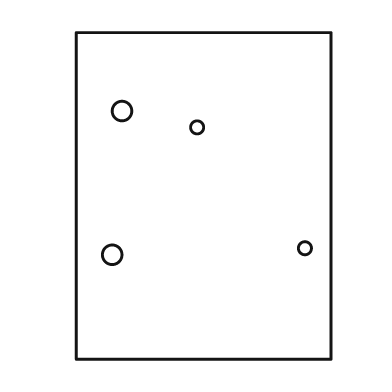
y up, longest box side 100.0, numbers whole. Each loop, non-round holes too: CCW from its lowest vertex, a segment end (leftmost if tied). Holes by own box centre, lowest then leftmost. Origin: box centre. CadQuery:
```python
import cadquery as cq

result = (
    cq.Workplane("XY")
    .moveTo(-39.0, -50.0)
    .lineTo(39.0, -50.0)
    .lineTo(39.0, 50.0)
    .lineTo(-39.0, 50.0)
    .close()
    .moveTo(-28.0, -18.0)
    .circle(3.0)
    .moveTo(31.0, -16.0)
    .circle(2.0)
    .moveTo(-2.0, 21.0)
    .circle(2.0)
    .moveTo(-25.0, 26.0)
    .circle(3.0)
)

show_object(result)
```